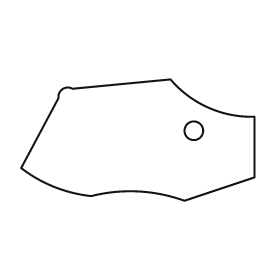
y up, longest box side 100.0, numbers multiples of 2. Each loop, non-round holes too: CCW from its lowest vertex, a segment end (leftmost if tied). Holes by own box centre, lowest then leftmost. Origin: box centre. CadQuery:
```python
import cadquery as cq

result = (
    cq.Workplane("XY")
    .moveTo(20.0, -26.0)
    .lineTo(50.0, -16.0)
    .lineTo(50.0, 10.0)
    .threePointArc((30.0, 14.0), (14.0, 26.0))
    .lineTo(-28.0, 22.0)
    .threePointArc((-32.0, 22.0), (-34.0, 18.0))
    .lineTo(-50.0, -12.0)
    .threePointArc((-36.0, -20.0), (-20.0, -24.0))
    .threePointArc((0.0, -22.0), (20.0, -26.0))
    .close()
    .moveTo(24.0, 4.0)
    .circle(4.0)
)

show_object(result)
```